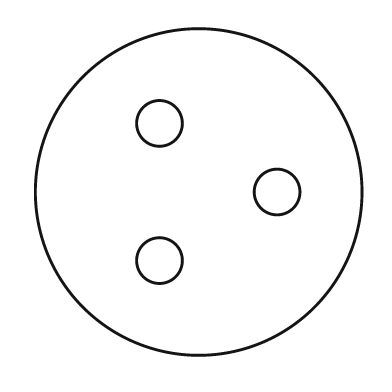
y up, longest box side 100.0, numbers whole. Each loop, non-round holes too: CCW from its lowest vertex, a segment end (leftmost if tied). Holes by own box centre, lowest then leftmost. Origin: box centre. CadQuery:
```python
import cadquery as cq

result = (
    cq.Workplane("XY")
    .moveTo(0.0, 0.0)
    .circle(50.0)
    .moveTo(-12.0, -21.0)
    .circle(7.0)
    .moveTo(24.0, 0.0)
    .circle(7.0)
    .moveTo(-12.0, 21.0)
    .circle(7.0)
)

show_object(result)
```